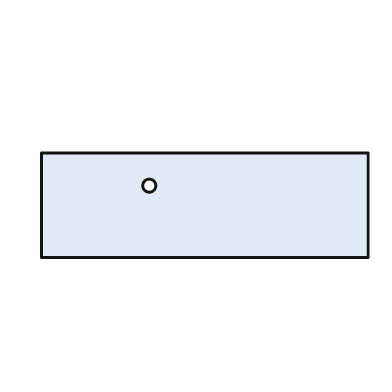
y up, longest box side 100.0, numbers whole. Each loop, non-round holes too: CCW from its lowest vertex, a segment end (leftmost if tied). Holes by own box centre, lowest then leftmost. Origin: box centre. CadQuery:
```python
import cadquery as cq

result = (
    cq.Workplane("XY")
    .moveTo(-50.0, -16.0)
    .lineTo(50.0, -16.0)
    .lineTo(50.0, 16.0)
    .lineTo(-50.0, 16.0)
    .close()
    .moveTo(-17.0, 6.0)
    .circle(2.0)
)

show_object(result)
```